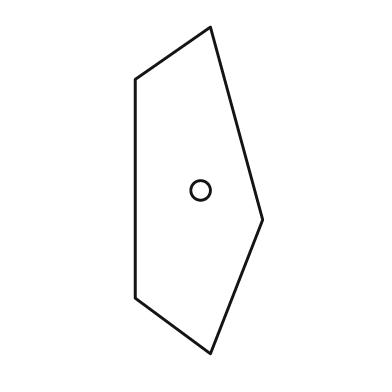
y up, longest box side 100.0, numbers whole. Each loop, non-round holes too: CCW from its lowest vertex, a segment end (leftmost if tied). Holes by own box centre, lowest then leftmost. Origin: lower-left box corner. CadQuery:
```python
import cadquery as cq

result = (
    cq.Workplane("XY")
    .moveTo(23.0, 0.0)
    .lineTo(39.0, 41.0)
    .lineTo(23.0, 100.0)
    .lineTo(0.0, 84.0)
    .lineTo(0.0, 17.0)
    .close()
    .moveTo(20.0, 50.0)
    .circle(3.0)
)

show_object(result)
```